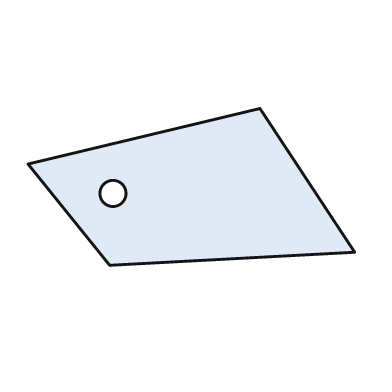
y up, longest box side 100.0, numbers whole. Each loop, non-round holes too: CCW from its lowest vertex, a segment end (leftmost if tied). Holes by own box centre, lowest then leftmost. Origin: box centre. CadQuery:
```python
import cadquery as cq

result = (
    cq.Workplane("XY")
    .moveTo(-25.0, -24.0)
    .lineTo(50.0, -20.0)
    .lineTo(21.0, 24.0)
    .lineTo(-50.0, 7.0)
    .close()
    .moveTo(-24.0, -2.0)
    .circle(4.0)
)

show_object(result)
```